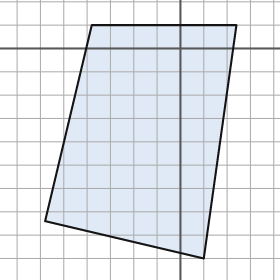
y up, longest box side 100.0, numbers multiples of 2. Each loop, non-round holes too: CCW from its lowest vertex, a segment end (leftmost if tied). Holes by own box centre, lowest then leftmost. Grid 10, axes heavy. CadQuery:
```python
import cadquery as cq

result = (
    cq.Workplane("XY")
    .moveTo(10.0, -90.0)
    .lineTo(24.0, 10.0)
    .lineTo(-38.0, 10.0)
    .lineTo(-58.0, -74.0)
    .close()
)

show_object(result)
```